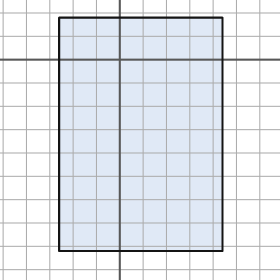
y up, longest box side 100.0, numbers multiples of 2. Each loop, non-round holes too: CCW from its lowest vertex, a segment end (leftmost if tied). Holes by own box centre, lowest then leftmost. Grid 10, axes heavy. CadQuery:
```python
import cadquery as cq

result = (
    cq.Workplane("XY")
    .moveTo(-26.0, -82.0)
    .lineTo(44.0, -82.0)
    .lineTo(44.0, 18.0)
    .lineTo(-26.0, 18.0)
    .close()
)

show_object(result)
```